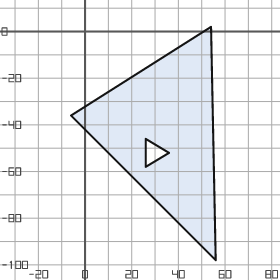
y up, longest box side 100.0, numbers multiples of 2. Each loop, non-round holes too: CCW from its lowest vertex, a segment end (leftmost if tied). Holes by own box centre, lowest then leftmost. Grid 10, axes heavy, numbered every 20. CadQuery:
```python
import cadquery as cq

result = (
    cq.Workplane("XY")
    .moveTo(56.0, -98.0)
    .lineTo(54.0, 2.0)
    .lineTo(-6.0, -36.0)
    .close()
    .moveTo(26.0, -58.0)
    .lineTo(36.0, -52.0)
    .lineTo(26.0, -46.0)
    .close()
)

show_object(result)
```